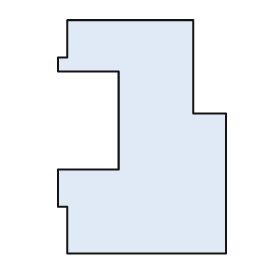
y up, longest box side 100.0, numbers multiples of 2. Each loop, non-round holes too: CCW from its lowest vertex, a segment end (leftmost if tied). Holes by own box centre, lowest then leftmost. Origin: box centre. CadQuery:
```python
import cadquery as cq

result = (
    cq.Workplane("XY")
    .moveTo(-32.0, -50.0)
    .lineTo(36.0, -50.0)
    .lineTo(36.0, 10.0)
    .lineTo(22.0, 10.0)
    .lineTo(22.0, 50.0)
    .lineTo(-32.0, 50.0)
    .lineTo(-32.0, 34.0)
    .lineTo(-36.0, 34.0)
    .lineTo(-36.0, 28.0)
    .lineTo(-10.0, 28.0)
    .lineTo(-10.0, -14.0)
    .lineTo(-36.0, -14.0)
    .lineTo(-36.0, -30.0)
    .lineTo(-32.0, -30.0)
    .close()
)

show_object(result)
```